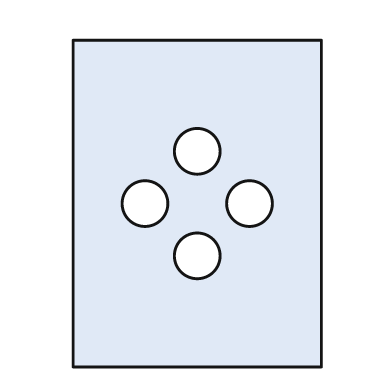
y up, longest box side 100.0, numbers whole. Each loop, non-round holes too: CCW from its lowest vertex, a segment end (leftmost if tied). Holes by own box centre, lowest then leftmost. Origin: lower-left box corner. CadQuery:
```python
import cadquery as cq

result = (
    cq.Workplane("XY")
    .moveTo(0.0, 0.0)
    .lineTo(76.0, 0.0)
    .lineTo(76.0, 100.0)
    .lineTo(0.0, 100.0)
    .close()
    .moveTo(38.0, 34.0)
    .circle(7.0)
    .moveTo(22.0, 50.0)
    .circle(7.0)
    .moveTo(54.0, 50.0)
    .circle(7.0)
    .moveTo(38.0, 66.0)
    .circle(7.0)
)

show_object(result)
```